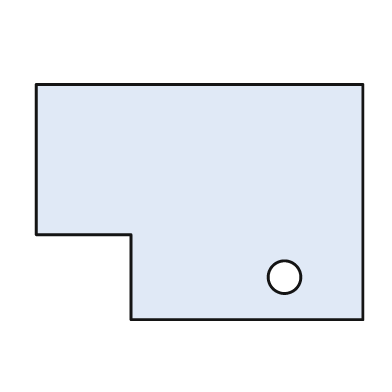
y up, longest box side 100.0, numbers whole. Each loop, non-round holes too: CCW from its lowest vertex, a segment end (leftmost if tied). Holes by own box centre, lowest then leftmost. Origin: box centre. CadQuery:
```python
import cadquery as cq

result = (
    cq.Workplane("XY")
    .moveTo(-21.0, -36.0)
    .lineTo(50.0, -36.0)
    .lineTo(50.0, 36.0)
    .lineTo(-50.0, 36.0)
    .lineTo(-50.0, -10.0)
    .lineTo(-21.0, -10.0)
    .close()
    .moveTo(26.0, -23.0)
    .circle(5.0)
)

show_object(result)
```